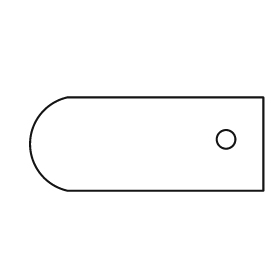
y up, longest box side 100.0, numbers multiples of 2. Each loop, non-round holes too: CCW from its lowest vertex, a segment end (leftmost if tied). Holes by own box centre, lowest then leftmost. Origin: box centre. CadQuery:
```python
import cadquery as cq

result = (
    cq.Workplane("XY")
    .moveTo(-34.0, -20.0)
    .lineTo(50.0, -20.0)
    .lineTo(50.0, 20.0)
    .lineTo(-34.0, 20.0)
    .threePointArc((-50.0, 0.0), (-34.0, -20.0))
    .close()
    .moveTo(34.0, 2.0)
    .circle(4.0)
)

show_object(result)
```